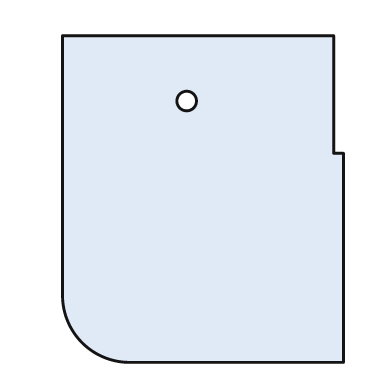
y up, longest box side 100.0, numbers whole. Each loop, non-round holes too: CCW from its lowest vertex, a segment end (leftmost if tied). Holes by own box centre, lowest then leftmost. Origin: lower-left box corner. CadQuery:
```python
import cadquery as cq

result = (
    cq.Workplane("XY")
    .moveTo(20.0, 0.0)
    .lineTo(86.0, 0.0)
    .lineTo(86.0, 64.0)
    .lineTo(83.0, 64.0)
    .lineTo(83.0, 100.0)
    .lineTo(0.0, 100.0)
    .lineTo(0.0, 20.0)
    .threePointArc((6.0, 6.0), (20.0, 0.0))
    .close()
    .moveTo(38.0, 80.0)
    .circle(3.0)
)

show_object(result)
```